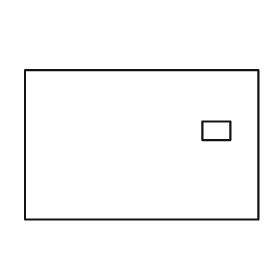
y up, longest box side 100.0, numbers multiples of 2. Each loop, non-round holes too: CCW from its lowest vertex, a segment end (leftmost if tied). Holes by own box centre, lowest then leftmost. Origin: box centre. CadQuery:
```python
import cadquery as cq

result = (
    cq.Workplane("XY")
    .moveTo(-50.0, -32.0)
    .lineTo(50.0, -32.0)
    .lineTo(50.0, 32.0)
    .lineTo(-50.0, 32.0)
    .close()
    .moveTo(26.0, 2.0)
    .lineTo(38.0, 2.0)
    .lineTo(38.0, 10.0)
    .lineTo(26.0, 10.0)
    .close()
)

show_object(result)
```